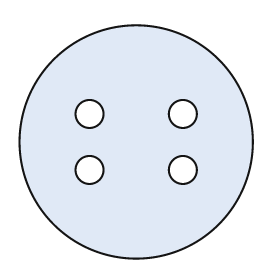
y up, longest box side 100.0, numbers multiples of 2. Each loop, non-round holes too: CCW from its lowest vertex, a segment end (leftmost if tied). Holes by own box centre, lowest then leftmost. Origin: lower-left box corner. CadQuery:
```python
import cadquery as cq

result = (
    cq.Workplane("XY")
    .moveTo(50.0, 50.0)
    .circle(50.0)
    .moveTo(30.0, 38.0)
    .circle(6.0)
    .moveTo(70.0, 38.0)
    .circle(6.0)
    .moveTo(30.0, 62.0)
    .circle(6.0)
    .moveTo(70.0, 62.0)
    .circle(6.0)
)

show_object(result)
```